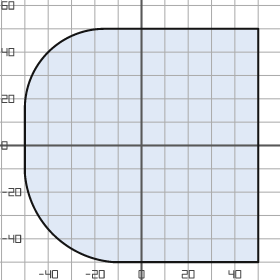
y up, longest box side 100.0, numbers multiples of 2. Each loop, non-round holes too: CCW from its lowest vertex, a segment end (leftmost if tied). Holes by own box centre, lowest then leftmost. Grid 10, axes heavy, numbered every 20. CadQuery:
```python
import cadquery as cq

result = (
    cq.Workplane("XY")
    .moveTo(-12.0, -50.0)
    .lineTo(50.0, -50.0)
    .lineTo(50.0, 50.0)
    .lineTo(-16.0, 50.0)
    .threePointArc((-40.0, 40.0), (-50.0, 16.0))
    .lineTo(-50.0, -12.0)
    .threePointArc((-38.0, -38.0), (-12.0, -50.0))
    .close()
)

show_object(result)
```